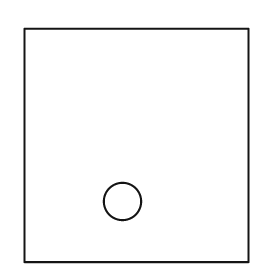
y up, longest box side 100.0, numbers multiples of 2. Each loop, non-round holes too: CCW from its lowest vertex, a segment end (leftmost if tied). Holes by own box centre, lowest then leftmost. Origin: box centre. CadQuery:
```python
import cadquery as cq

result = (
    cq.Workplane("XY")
    .moveTo(-48.0, -50.0)
    .lineTo(48.0, -50.0)
    .lineTo(48.0, 50.0)
    .lineTo(-48.0, 50.0)
    .close()
    .moveTo(-6.0, -24.0)
    .circle(8.0)
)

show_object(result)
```